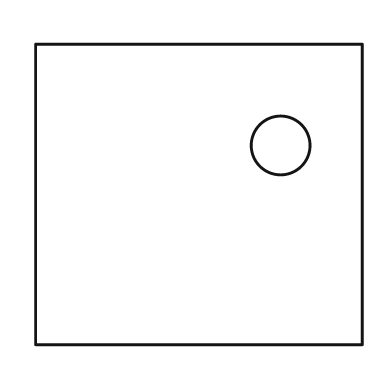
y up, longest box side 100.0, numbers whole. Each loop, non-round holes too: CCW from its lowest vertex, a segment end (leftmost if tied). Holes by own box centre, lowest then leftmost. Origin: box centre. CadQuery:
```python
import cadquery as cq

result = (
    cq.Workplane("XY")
    .moveTo(-50.0, -46.0)
    .lineTo(50.0, -46.0)
    .lineTo(50.0, 46.0)
    .lineTo(-50.0, 46.0)
    .close()
    .moveTo(25.0, 15.0)
    .circle(9.0)
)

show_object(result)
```